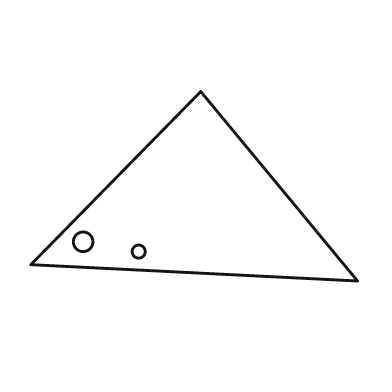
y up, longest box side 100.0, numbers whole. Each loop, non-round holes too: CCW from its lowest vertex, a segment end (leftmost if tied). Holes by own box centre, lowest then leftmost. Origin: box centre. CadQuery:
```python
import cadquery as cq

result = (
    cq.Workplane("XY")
    .moveTo(50.0, -29.0)
    .lineTo(2.0, 29.0)
    .lineTo(-50.0, -24.0)
    .close()
    .moveTo(-17.0, -20.0)
    .circle(2.0)
    .moveTo(-34.0, -17.0)
    .circle(3.0)
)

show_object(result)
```